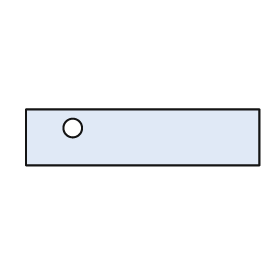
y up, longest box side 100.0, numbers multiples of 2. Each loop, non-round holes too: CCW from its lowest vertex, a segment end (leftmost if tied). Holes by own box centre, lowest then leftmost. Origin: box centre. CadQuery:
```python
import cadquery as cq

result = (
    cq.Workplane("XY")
    .moveTo(-50.0, -12.0)
    .lineTo(50.0, -12.0)
    .lineTo(50.0, 12.0)
    .lineTo(-50.0, 12.0)
    .close()
    .moveTo(-30.0, 4.0)
    .circle(4.0)
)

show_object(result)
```